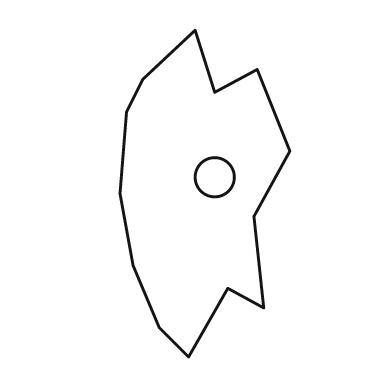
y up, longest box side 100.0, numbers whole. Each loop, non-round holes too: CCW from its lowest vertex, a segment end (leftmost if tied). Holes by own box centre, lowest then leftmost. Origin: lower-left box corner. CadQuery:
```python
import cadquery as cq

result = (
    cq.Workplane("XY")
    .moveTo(21.0, 0.0)
    .lineTo(33.0, 21.0)
    .lineTo(44.0, 15.0)
    .lineTo(41.0, 43.0)
    .lineTo(52.0, 63.0)
    .lineTo(42.0, 88.0)
    .lineTo(29.0, 81.0)
    .lineTo(23.0, 100.0)
    .lineTo(7.0, 85.0)
    .lineTo(2.0, 75.0)
    .lineTo(0.0, 50.0)
    .lineTo(4.0, 28.0)
    .lineTo(12.0, 9.0)
    .close()
    .moveTo(29.0, 55.0)
    .circle(6.0)
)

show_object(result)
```